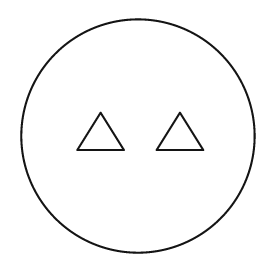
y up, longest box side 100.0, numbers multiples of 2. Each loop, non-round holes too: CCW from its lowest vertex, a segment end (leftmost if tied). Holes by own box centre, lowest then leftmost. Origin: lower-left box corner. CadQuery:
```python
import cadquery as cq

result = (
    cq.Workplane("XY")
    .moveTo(50.0, 50.0)
    .circle(50.0)
    .moveTo(24.0, 44.0)
    .lineTo(44.0, 44.0)
    .lineTo(34.0, 60.0)
    .close()
    .moveTo(58.0, 44.0)
    .lineTo(78.0, 44.0)
    .lineTo(68.0, 60.0)
    .close()
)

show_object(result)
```